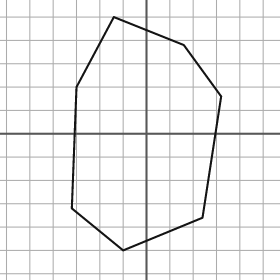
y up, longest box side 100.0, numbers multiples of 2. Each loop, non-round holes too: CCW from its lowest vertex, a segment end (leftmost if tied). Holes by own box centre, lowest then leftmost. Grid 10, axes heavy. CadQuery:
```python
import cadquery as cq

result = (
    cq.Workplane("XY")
    .moveTo(-10.0, -50.0)
    .lineTo(24.0, -36.0)
    .lineTo(32.0, 16.0)
    .lineTo(16.0, 38.0)
    .lineTo(-14.0, 50.0)
    .lineTo(-30.0, 20.0)
    .lineTo(-32.0, -32.0)
    .close()
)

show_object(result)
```